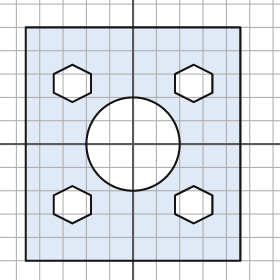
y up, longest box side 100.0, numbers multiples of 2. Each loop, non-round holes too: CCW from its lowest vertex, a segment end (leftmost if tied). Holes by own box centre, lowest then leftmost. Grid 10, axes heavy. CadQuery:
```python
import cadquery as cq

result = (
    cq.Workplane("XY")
    .moveTo(-46.0, -50.0)
    .lineTo(46.0, -50.0)
    .lineTo(46.0, 50.0)
    .lineTo(-46.0, 50.0)
    .close()
    .moveTo(-26.0, -34.0)
    .lineTo(-18.0, -30.0)
    .lineTo(-18.0, -22.0)
    .lineTo(-26.0, -18.0)
    .lineTo(-34.0, -22.0)
    .lineTo(-34.0, -30.0)
    .close()
    .moveTo(26.0, -34.0)
    .lineTo(34.0, -30.0)
    .lineTo(34.0, -22.0)
    .lineTo(26.0, -18.0)
    .lineTo(18.0, -22.0)
    .lineTo(18.0, -30.0)
    .close()
    .moveTo(0.0, 0.0)
    .circle(20.0)
    .moveTo(-26.0, 18.0)
    .lineTo(-18.0, 22.0)
    .lineTo(-18.0, 30.0)
    .lineTo(-26.0, 34.0)
    .lineTo(-34.0, 30.0)
    .lineTo(-34.0, 22.0)
    .close()
    .moveTo(26.0, 18.0)
    .lineTo(34.0, 22.0)
    .lineTo(34.0, 30.0)
    .lineTo(26.0, 34.0)
    .lineTo(18.0, 30.0)
    .lineTo(18.0, 22.0)
    .close()
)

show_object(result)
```